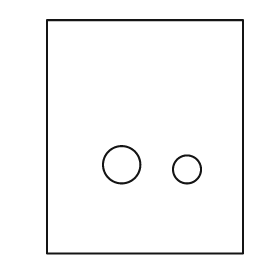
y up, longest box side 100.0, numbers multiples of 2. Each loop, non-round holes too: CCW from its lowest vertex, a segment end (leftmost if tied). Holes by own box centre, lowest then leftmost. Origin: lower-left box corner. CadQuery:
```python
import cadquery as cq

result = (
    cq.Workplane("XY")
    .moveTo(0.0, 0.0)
    .lineTo(84.0, 0.0)
    .lineTo(84.0, 100.0)
    .lineTo(0.0, 100.0)
    .close()
    .moveTo(60.0, 36.0)
    .circle(6.0)
    .moveTo(32.0, 38.0)
    .circle(8.0)
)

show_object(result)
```